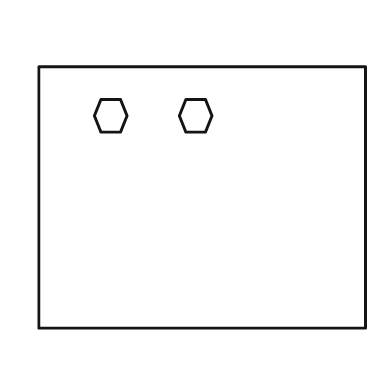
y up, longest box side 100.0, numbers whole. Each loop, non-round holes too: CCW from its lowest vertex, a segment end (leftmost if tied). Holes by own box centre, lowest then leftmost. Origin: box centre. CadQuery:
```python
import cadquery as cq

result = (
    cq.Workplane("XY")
    .moveTo(-50.0, -40.0)
    .lineTo(50.0, -40.0)
    .lineTo(50.0, 40.0)
    .lineTo(-50.0, 40.0)
    .close()
    .moveTo(-31.0, 20.0)
    .lineTo(-25.0, 20.0)
    .lineTo(-23.0, 25.0)
    .lineTo(-25.0, 30.0)
    .lineTo(-31.0, 30.0)
    .lineTo(-33.0, 25.0)
    .close()
    .moveTo(-5.0, 20.0)
    .lineTo(1.0, 20.0)
    .lineTo(3.0, 25.0)
    .lineTo(1.0, 30.0)
    .lineTo(-5.0, 30.0)
    .lineTo(-7.0, 25.0)
    .close()
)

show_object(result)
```